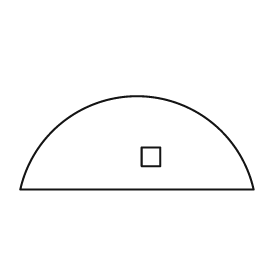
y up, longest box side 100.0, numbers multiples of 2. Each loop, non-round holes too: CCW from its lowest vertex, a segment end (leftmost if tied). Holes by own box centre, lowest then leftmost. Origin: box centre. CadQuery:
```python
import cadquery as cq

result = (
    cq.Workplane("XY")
    .moveTo(-50.0, -20.0)
    .lineTo(50.0, -20.0)
    .threePointArc((0.0, 20.0), (-50.0, -20.0))
    .close()
    .moveTo(2.0, -10.0)
    .lineTo(10.0, -10.0)
    .lineTo(10.0, -2.0)
    .lineTo(2.0, -2.0)
    .close()
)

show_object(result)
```